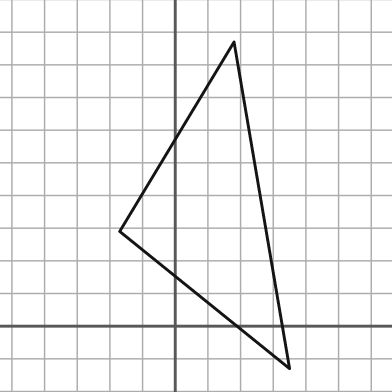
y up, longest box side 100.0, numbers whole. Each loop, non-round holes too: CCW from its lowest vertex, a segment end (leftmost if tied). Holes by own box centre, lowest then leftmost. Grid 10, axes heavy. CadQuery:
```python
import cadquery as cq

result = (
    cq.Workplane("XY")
    .moveTo(35.0, -13.0)
    .lineTo(18.0, 87.0)
    .lineTo(-17.0, 29.0)
    .close()
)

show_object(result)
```